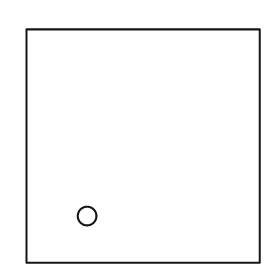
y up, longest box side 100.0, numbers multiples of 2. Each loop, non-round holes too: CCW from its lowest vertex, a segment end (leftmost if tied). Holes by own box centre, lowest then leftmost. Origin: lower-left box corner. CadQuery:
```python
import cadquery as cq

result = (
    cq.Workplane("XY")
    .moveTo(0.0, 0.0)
    .lineTo(100.0, 0.0)
    .lineTo(100.0, 100.0)
    .lineTo(0.0, 100.0)
    .close()
    .moveTo(26.0, 20.0)
    .circle(4.0)
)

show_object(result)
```